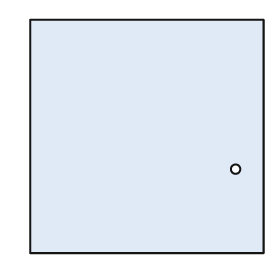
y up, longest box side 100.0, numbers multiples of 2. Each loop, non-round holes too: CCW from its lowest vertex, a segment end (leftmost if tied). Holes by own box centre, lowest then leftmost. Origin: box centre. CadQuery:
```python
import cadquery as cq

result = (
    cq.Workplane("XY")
    .moveTo(-50.0, -50.0)
    .lineTo(50.0, -50.0)
    .lineTo(50.0, 50.0)
    .lineTo(-50.0, 50.0)
    .close()
    .moveTo(38.0, -14.0)
    .circle(2.0)
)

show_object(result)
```